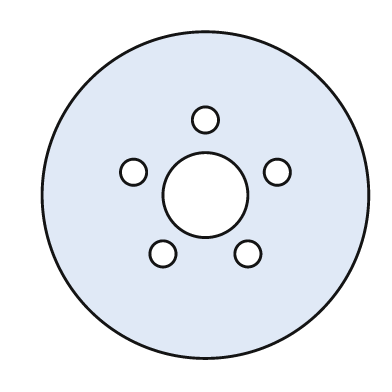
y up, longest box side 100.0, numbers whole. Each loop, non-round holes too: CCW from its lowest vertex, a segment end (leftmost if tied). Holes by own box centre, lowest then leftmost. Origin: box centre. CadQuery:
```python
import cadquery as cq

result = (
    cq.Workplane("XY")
    .moveTo(0.0, 0.0)
    .circle(50.0)
    .moveTo(-13.0, -18.0)
    .circle(4.0)
    .moveTo(13.0, -18.0)
    .circle(4.0)
    .moveTo(0.0, 0.0)
    .circle(13.0)
    .moveTo(-22.0, 7.0)
    .circle(4.0)
    .moveTo(22.0, 7.0)
    .circle(4.0)
    .moveTo(0.0, 23.0)
    .circle(4.0)
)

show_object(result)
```